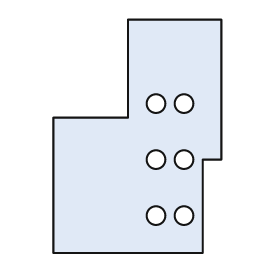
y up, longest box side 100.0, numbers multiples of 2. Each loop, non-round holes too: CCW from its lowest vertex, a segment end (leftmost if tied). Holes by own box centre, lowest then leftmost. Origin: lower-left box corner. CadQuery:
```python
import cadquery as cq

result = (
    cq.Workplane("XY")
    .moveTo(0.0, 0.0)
    .lineTo(64.0, 0.0)
    .lineTo(64.0, 40.0)
    .lineTo(72.0, 40.0)
    .lineTo(72.0, 100.0)
    .lineTo(32.0, 100.0)
    .lineTo(32.0, 58.0)
    .lineTo(0.0, 58.0)
    .close()
    .moveTo(44.0, 16.0)
    .circle(4.0)
    .moveTo(56.0, 16.0)
    .circle(4.0)
    .moveTo(44.0, 40.0)
    .circle(4.0)
    .moveTo(56.0, 40.0)
    .circle(4.0)
    .moveTo(44.0, 64.0)
    .circle(4.0)
    .moveTo(56.0, 64.0)
    .circle(4.0)
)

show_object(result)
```